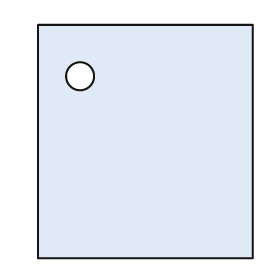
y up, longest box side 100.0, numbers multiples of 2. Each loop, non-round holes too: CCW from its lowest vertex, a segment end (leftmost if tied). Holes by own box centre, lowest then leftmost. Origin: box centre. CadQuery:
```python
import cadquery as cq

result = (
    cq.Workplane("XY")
    .moveTo(-46.0, -50.0)
    .lineTo(46.0, -50.0)
    .lineTo(46.0, 50.0)
    .lineTo(-46.0, 50.0)
    .close()
    .moveTo(-28.0, 28.0)
    .circle(6.0)
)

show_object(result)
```